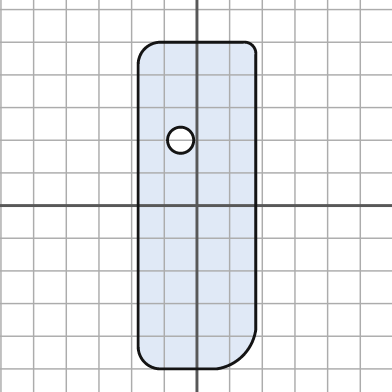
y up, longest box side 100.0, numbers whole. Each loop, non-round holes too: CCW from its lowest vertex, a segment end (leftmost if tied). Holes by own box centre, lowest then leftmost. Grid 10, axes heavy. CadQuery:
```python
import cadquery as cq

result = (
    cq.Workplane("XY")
    .moveTo(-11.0, -50.0)
    .lineTo(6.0, -50.0)
    .threePointArc((14.0, -46.0), (18.0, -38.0))
    .lineTo(18.0, 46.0)
    .threePointArc((17.0, 49.0), (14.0, 50.0))
    .lineTo(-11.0, 50.0)
    .threePointArc((-16.0, 48.0), (-18.0, 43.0))
    .lineTo(-18.0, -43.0)
    .threePointArc((-16.0, -48.0), (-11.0, -50.0))
    .close()
    .moveTo(-5.0, 20.0)
    .circle(4.0)
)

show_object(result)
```